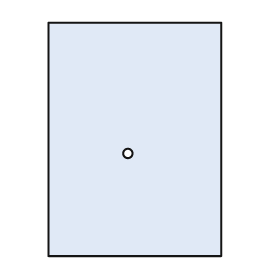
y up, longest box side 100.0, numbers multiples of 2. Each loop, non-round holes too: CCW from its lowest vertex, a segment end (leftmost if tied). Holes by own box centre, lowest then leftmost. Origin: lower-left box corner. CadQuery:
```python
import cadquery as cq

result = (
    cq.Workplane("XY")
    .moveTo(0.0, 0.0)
    .lineTo(74.0, 0.0)
    .lineTo(74.0, 100.0)
    .lineTo(0.0, 100.0)
    .close()
    .moveTo(34.0, 44.0)
    .circle(2.0)
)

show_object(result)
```